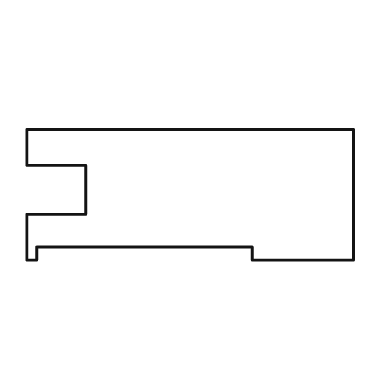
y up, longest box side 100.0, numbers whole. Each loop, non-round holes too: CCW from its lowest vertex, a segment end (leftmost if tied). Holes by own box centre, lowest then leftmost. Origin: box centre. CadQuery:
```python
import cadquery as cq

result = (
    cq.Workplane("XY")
    .moveTo(-50.0, -20.0)
    .lineTo(-47.0, -20.0)
    .lineTo(-47.0, -16.0)
    .lineTo(19.0, -16.0)
    .lineTo(19.0, -20.0)
    .lineTo(50.0, -20.0)
    .lineTo(50.0, 20.0)
    .lineTo(-50.0, 20.0)
    .lineTo(-50.0, 9.0)
    .lineTo(-32.0, 9.0)
    .lineTo(-32.0, -6.0)
    .lineTo(-50.0, -6.0)
    .close()
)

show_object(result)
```